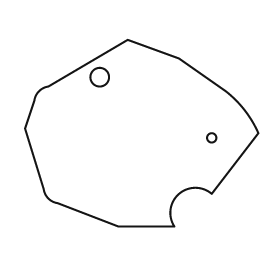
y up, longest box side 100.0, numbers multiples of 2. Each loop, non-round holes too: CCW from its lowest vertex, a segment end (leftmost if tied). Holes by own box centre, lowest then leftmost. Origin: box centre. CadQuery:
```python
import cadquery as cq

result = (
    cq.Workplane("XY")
    .moveTo(-10.0, -40.0)
    .lineTo(14.0, -40.0)
    .threePointArc((16.0, -26.0), (30.0, -26.0))
    .lineTo(50.0, 0.0)
    .threePointArc((44.0, 10.0), (36.0, 18.0))
    .lineTo(16.0, 32.0)
    .lineTo(-6.0, 40.0)
    .lineTo(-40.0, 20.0)
    .threePointArc((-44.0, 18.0), (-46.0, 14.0))
    .lineTo(-50.0, 2.0)
    .lineTo(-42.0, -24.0)
    .threePointArc((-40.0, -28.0), (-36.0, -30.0))
    .close()
    .moveTo(30.0, -2.0)
    .circle(2.0)
    .moveTo(-18.0, 24.0)
    .circle(4.0)
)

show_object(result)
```